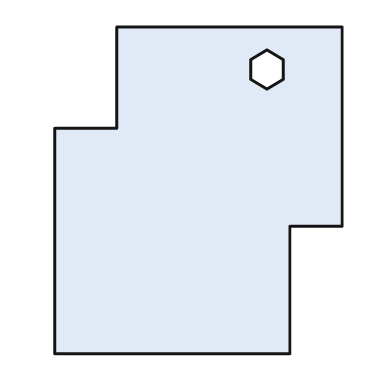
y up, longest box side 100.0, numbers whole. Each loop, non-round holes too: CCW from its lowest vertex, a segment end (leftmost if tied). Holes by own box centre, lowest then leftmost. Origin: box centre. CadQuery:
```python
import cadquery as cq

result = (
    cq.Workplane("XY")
    .moveTo(-44.0, -50.0)
    .lineTo(28.0, -50.0)
    .lineTo(28.0, -11.0)
    .lineTo(44.0, -11.0)
    .lineTo(44.0, 50.0)
    .lineTo(-25.0, 50.0)
    .lineTo(-25.0, 19.0)
    .lineTo(-44.0, 19.0)
    .close()
    .moveTo(21.0, 31.0)
    .lineTo(26.0, 34.0)
    .lineTo(26.0, 40.0)
    .lineTo(21.0, 43.0)
    .lineTo(16.0, 40.0)
    .lineTo(16.0, 34.0)
    .close()
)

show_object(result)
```